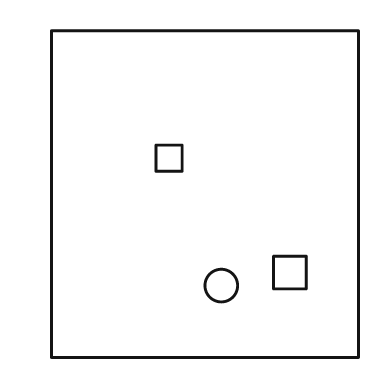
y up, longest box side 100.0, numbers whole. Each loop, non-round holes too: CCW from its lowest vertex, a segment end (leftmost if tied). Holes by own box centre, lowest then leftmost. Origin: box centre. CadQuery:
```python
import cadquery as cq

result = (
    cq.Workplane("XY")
    .moveTo(-47.0, -50.0)
    .lineTo(47.0, -50.0)
    .lineTo(47.0, 50.0)
    .lineTo(-47.0, 50.0)
    .close()
    .moveTo(5.0, -28.0)
    .circle(5.0)
    .moveTo(21.0, -29.0)
    .lineTo(31.0, -29.0)
    .lineTo(31.0, -19.0)
    .lineTo(21.0, -19.0)
    .close()
    .moveTo(-15.0, 7.0)
    .lineTo(-7.0, 7.0)
    .lineTo(-7.0, 15.0)
    .lineTo(-15.0, 15.0)
    .close()
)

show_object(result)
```